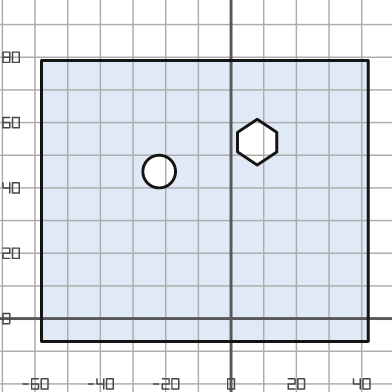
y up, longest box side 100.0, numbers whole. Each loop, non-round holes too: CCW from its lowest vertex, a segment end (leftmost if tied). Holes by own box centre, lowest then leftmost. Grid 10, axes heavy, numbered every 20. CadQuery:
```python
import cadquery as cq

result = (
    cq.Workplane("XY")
    .moveTo(-58.0, -7.0)
    .lineTo(42.0, -7.0)
    .lineTo(42.0, 79.0)
    .lineTo(-58.0, 79.0)
    .close()
    .moveTo(-22.0, 45.0)
    .circle(5.0)
    .moveTo(8.0, 47.0)
    .lineTo(14.0, 51.0)
    .lineTo(14.0, 57.0)
    .lineTo(8.0, 61.0)
    .lineTo(2.0, 57.0)
    .lineTo(2.0, 51.0)
    .close()
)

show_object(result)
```